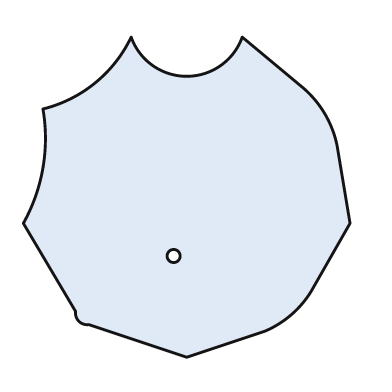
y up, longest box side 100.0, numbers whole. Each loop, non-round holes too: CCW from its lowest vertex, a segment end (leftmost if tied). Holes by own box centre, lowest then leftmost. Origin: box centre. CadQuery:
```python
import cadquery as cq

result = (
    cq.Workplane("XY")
    .moveTo(0.0, -49.0)
    .lineTo(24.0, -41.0)
    .threePointArc((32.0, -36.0), (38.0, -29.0))
    .lineTo(50.0, -8.0)
    .lineTo(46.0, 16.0)
    .threePointArc((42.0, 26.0), (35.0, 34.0))
    .lineTo(17.0, 49.0)
    .threePointArc((0.0, 37.0), (-17.0, 49.0))
    .threePointArc((-28.0, 35.0), (-44.0, 27.0))
    .threePointArc((-44.0, 9.0), (-50.0, -8.0))
    .lineTo(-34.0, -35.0)
    .threePointArc((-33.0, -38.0), (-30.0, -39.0))
    .close()
    .moveTo(-4.0, -18.0)
    .circle(2.0)
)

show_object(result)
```